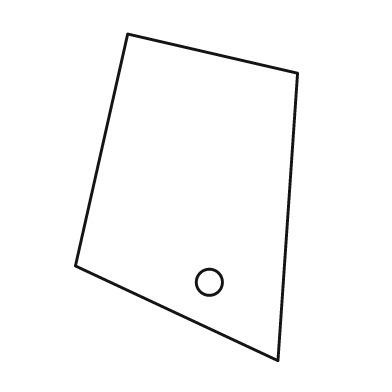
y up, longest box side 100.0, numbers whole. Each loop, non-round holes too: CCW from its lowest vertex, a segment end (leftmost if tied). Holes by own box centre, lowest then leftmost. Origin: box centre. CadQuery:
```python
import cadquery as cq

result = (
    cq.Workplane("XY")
    .moveTo(28.0, -50.0)
    .lineTo(34.0, 38.0)
    .lineTo(-18.0, 50.0)
    .lineTo(-34.0, -21.0)
    .close()
    .moveTo(7.0, -26.0)
    .circle(4.0)
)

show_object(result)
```